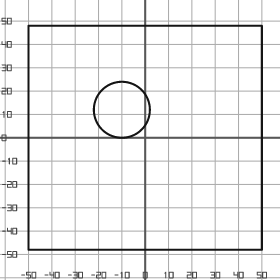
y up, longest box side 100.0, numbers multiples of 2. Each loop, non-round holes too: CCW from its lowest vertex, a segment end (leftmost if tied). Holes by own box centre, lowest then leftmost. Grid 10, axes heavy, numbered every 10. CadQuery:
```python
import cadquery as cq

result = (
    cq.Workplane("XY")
    .moveTo(-50.0, -48.0)
    .lineTo(50.0, -48.0)
    .lineTo(50.0, 48.0)
    .lineTo(-50.0, 48.0)
    .close()
    .moveTo(-10.0, 12.0)
    .circle(12.0)
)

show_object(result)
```